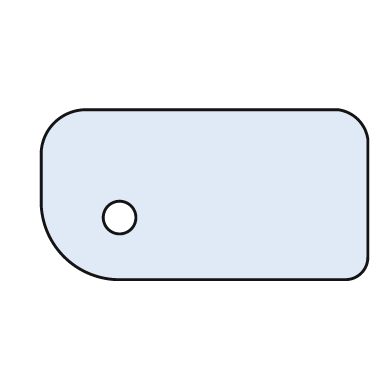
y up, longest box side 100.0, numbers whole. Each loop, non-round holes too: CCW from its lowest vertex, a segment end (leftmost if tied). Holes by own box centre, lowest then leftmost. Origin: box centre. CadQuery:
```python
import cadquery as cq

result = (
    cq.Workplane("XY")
    .moveTo(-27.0, -26.0)
    .lineTo(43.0, -26.0)
    .threePointArc((48.0, -24.0), (50.0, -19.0))
    .lineTo(50.0, 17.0)
    .threePointArc((47.0, 23.0), (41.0, 26.0))
    .lineTo(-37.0, 26.0)
    .threePointArc((-46.0, 22.0), (-50.0, 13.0))
    .lineTo(-50.0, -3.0)
    .threePointArc((-43.0, -19.0), (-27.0, -26.0))
    .close()
    .moveTo(-26.0, -7.0)
    .circle(5.0)
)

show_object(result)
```